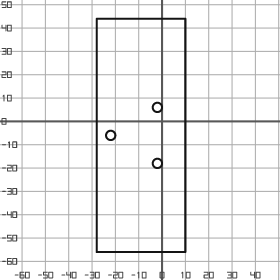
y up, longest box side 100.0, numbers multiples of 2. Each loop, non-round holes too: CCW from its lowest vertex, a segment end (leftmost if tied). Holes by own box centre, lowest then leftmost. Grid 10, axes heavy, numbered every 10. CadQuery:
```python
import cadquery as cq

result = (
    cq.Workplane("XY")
    .moveTo(-28.0, -56.0)
    .lineTo(10.0, -56.0)
    .lineTo(10.0, 44.0)
    .lineTo(-28.0, 44.0)
    .close()
    .moveTo(-2.0, -18.0)
    .circle(2.0)
    .moveTo(-22.0, -6.0)
    .circle(2.0)
    .moveTo(-2.0, 6.0)
    .circle(2.0)
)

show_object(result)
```